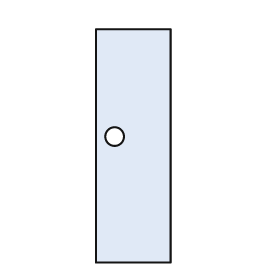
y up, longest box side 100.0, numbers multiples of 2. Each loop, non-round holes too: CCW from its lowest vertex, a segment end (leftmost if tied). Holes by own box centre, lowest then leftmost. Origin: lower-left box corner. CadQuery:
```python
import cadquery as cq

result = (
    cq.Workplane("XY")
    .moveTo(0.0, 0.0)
    .lineTo(32.0, 0.0)
    .lineTo(32.0, 100.0)
    .lineTo(0.0, 100.0)
    .close()
    .moveTo(8.0, 54.0)
    .circle(4.0)
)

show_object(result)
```